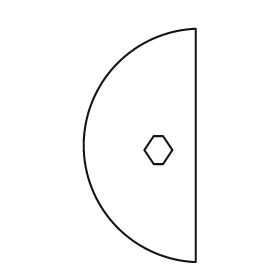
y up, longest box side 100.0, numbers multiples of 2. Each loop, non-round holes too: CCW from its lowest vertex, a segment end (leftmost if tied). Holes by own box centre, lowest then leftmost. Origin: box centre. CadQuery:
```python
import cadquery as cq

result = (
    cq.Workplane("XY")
    .moveTo(24.0, -50.0)
    .lineTo(24.0, 50.0)
    .threePointArc((-24.0, 0.0), (24.0, -50.0))
    .close()
    .moveTo(6.0, -8.0)
    .lineTo(10.0, -8.0)
    .lineTo(14.0, -2.0)
    .lineTo(10.0, 4.0)
    .lineTo(6.0, 4.0)
    .lineTo(2.0, -2.0)
    .close()
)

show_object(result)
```